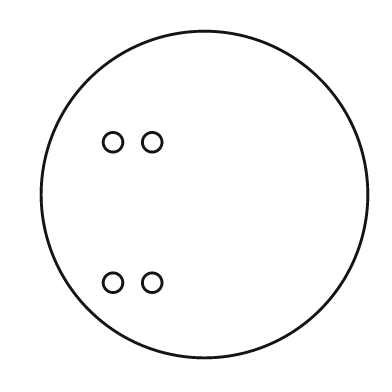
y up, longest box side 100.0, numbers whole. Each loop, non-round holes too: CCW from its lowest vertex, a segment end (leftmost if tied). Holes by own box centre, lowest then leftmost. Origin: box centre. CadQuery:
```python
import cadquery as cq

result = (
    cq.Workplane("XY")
    .moveTo(0.0, 0.0)
    .circle(50.0)
    .moveTo(-28.0, -27.0)
    .circle(3.0)
    .moveTo(-16.0, -27.0)
    .circle(3.0)
    .moveTo(-28.0, 16.0)
    .circle(3.0)
    .moveTo(-16.0, 16.0)
    .circle(3.0)
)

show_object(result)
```